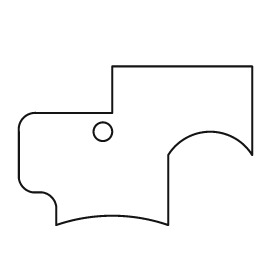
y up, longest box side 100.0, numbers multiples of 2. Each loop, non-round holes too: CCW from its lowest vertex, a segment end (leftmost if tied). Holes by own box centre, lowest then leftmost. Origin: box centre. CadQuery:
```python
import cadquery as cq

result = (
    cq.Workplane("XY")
    .moveTo(-34.0, -34.0)
    .threePointArc((-10.0, -30.0), (14.0, -34.0))
    .lineTo(14.0, -4.0)
    .threePointArc((32.0, 6.0), (50.0, -4.0))
    .lineTo(50.0, 34.0)
    .lineTo(-10.0, 34.0)
    .lineTo(-10.0, 14.0)
    .lineTo(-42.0, 14.0)
    .threePointArc((-48.0, 12.0), (-50.0, 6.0))
    .lineTo(-50.0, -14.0)
    .threePointArc((-48.0, -18.0), (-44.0, -20.0))
    .lineTo(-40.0, -20.0)
    .threePointArc((-36.0, -22.0), (-34.0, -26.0))
    .close()
    .moveTo(-14.0, 6.0)
    .circle(4.0)
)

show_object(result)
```